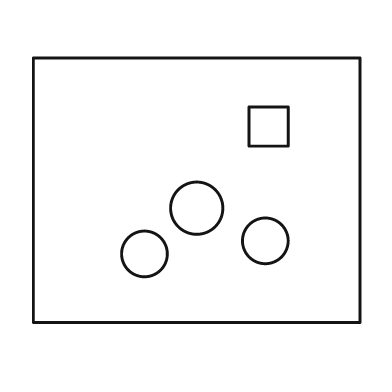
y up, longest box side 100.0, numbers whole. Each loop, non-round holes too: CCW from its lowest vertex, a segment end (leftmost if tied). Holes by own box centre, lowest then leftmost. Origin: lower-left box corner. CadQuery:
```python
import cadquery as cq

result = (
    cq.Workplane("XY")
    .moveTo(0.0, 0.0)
    .lineTo(100.0, 0.0)
    .lineTo(100.0, 81.0)
    .lineTo(0.0, 81.0)
    .close()
    .moveTo(34.0, 21.0)
    .circle(7.0)
    .moveTo(71.0, 25.0)
    .circle(7.0)
    .moveTo(50.0, 35.0)
    .circle(8.0)
    .moveTo(66.0, 54.0)
    .lineTo(78.0, 54.0)
    .lineTo(78.0, 66.0)
    .lineTo(66.0, 66.0)
    .close()
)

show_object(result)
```